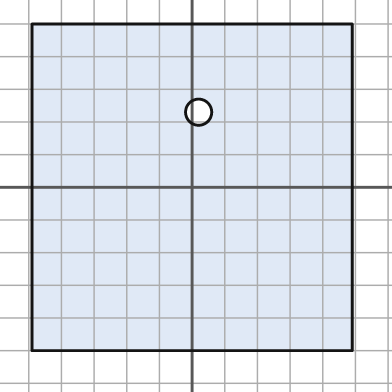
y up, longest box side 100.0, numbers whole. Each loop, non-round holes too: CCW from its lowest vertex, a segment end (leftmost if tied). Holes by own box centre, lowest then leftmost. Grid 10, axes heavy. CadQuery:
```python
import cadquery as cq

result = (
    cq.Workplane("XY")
    .moveTo(-49.0, -50.0)
    .lineTo(49.0, -50.0)
    .lineTo(49.0, 50.0)
    .lineTo(-49.0, 50.0)
    .close()
    .moveTo(2.0, 23.0)
    .circle(4.0)
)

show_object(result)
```